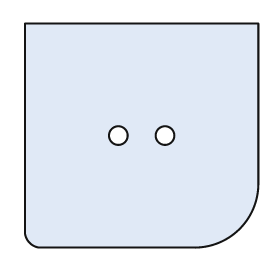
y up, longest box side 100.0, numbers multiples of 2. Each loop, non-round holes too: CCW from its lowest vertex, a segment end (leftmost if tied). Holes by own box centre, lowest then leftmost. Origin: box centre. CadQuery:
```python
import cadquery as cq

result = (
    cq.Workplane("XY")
    .moveTo(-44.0, -48.0)
    .lineTo(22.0, -48.0)
    .threePointArc((42.0, -40.0), (50.0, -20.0))
    .lineTo(50.0, 48.0)
    .lineTo(-50.0, 48.0)
    .lineTo(-50.0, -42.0)
    .threePointArc((-48.0, -46.0), (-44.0, -48.0))
    .close()
    .moveTo(-10.0, 0.0)
    .circle(4.0)
    .moveTo(10.0, 0.0)
    .circle(4.0)
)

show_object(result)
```